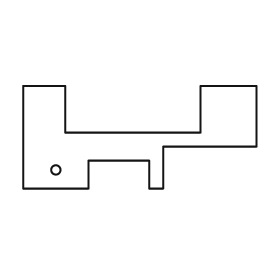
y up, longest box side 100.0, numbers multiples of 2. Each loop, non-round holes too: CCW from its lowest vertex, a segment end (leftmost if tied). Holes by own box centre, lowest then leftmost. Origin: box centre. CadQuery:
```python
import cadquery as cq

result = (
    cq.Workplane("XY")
    .moveTo(-50.0, -22.0)
    .lineTo(-22.0, -22.0)
    .lineTo(-22.0, -10.0)
    .lineTo(4.0, -10.0)
    .lineTo(4.0, -22.0)
    .lineTo(10.0, -22.0)
    .lineTo(10.0, -4.0)
    .lineTo(50.0, -4.0)
    .lineTo(50.0, 22.0)
    .lineTo(26.0, 22.0)
    .lineTo(26.0, 2.0)
    .lineTo(-32.0, 2.0)
    .lineTo(-32.0, 22.0)
    .lineTo(-50.0, 22.0)
    .close()
    .moveTo(-36.0, -14.0)
    .circle(2.0)
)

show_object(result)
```